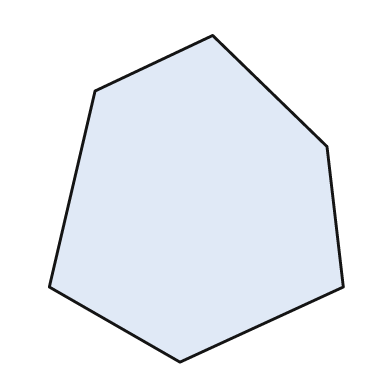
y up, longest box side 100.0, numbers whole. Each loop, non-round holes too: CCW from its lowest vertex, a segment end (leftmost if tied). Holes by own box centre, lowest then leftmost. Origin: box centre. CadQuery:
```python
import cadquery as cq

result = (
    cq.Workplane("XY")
    .moveTo(-5.0, -50.0)
    .lineTo(45.0, -27.0)
    .lineTo(40.0, 16.0)
    .lineTo(5.0, 50.0)
    .lineTo(-31.0, 33.0)
    .lineTo(-45.0, -27.0)
    .close()
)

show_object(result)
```